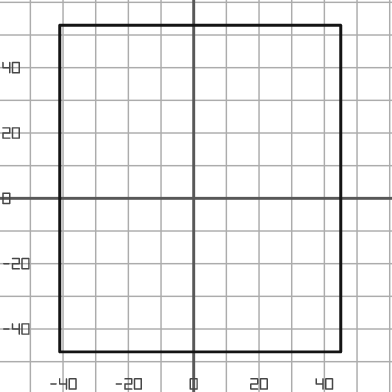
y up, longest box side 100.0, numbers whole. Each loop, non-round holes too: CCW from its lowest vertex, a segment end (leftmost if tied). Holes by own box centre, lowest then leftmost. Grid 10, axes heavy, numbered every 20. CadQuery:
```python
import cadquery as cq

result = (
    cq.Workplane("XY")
    .moveTo(-41.0, -47.0)
    .lineTo(45.0, -47.0)
    .lineTo(45.0, 53.0)
    .lineTo(-41.0, 53.0)
    .close()
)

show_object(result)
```